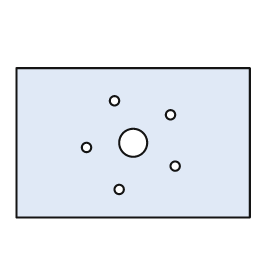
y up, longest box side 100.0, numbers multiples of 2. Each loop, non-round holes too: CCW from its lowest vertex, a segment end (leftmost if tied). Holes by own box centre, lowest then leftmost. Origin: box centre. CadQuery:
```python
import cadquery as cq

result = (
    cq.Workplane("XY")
    .moveTo(-50.0, -32.0)
    .lineTo(50.0, -32.0)
    .lineTo(50.0, 32.0)
    .lineTo(-50.0, 32.0)
    .close()
    .moveTo(-6.0, -20.0)
    .circle(2.0)
    .moveTo(18.0, -10.0)
    .circle(2.0)
    .moveTo(-20.0, -2.0)
    .circle(2.0)
    .moveTo(0.0, 0.0)
    .circle(6.0)
    .moveTo(16.0, 12.0)
    .circle(2.0)
    .moveTo(-8.0, 18.0)
    .circle(2.0)
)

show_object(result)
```